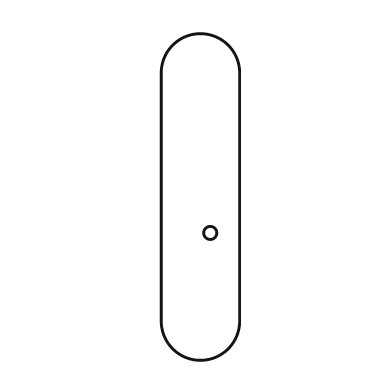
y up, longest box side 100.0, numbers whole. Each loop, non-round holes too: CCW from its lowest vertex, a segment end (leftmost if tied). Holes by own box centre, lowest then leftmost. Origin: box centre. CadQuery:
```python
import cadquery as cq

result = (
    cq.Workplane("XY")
    .moveTo(-12.0, -38.0)
    .threePointArc((0.0, -50.0), (12.0, -38.0))
    .lineTo(12.0, 38.0)
    .threePointArc((0.0, 50.0), (-12.0, 38.0))
    .close()
    .moveTo(3.0, -11.0)
    .circle(2.0)
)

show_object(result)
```